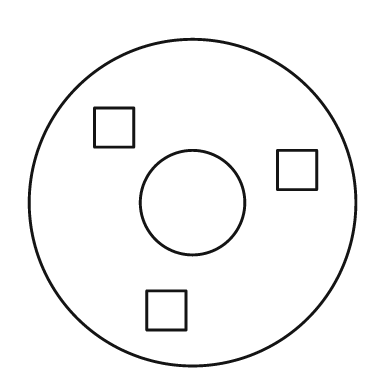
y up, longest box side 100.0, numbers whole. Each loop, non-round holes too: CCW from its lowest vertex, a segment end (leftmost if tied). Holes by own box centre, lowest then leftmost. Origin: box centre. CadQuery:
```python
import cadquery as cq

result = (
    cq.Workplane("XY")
    .moveTo(0.0, 0.0)
    .circle(50.0)
    .moveTo(-14.0, -39.0)
    .lineTo(-2.0, -39.0)
    .lineTo(-2.0, -27.0)
    .lineTo(-14.0, -27.0)
    .close()
    .moveTo(0.0, 0.0)
    .circle(16.0)
    .moveTo(26.0, 4.0)
    .lineTo(38.0, 4.0)
    .lineTo(38.0, 16.0)
    .lineTo(26.0, 16.0)
    .close()
    .moveTo(-30.0, 17.0)
    .lineTo(-18.0, 17.0)
    .lineTo(-18.0, 29.0)
    .lineTo(-30.0, 29.0)
    .close()
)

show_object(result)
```